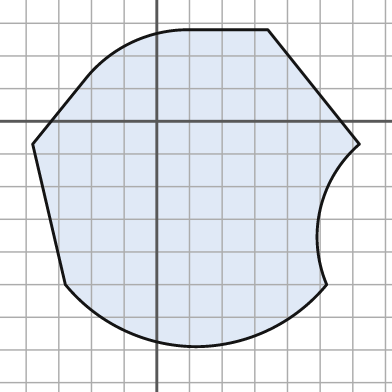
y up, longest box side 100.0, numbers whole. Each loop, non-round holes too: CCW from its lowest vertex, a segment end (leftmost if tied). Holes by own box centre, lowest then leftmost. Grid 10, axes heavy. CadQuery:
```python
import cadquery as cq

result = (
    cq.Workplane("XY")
    .moveTo(12.0, -69.0)
    .threePointArc((34.0, -64.0), (52.0, -50.0))
    .threePointArc((50.0, -27.0), (62.0, -7.0))
    .lineTo(34.0, 28.0)
    .lineTo(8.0, 28.0)
    .threePointArc((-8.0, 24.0), (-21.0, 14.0))
    .lineTo(-38.0, -7.0)
    .lineTo(-28.0, -50.0)
    .threePointArc((-10.0, -64.0), (12.0, -69.0))
    .close()
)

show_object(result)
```